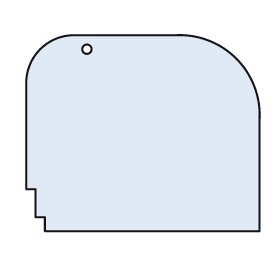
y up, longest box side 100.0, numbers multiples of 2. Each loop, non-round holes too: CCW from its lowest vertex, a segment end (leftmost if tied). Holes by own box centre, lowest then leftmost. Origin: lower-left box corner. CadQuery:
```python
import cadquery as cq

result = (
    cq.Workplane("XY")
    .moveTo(8.0, 0.0)
    .lineTo(100.0, 0.0)
    .lineTo(100.0, 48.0)
    .threePointArc((90.0, 74.0), (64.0, 84.0))
    .lineTo(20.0, 84.0)
    .threePointArc((6.0, 78.0), (0.0, 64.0))
    .lineTo(0.0, 18.0)
    .lineTo(4.0, 18.0)
    .lineTo(4.0, 6.0)
    .lineTo(8.0, 6.0)
    .close()
    .moveTo(26.0, 78.0)
    .circle(2.0)
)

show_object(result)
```